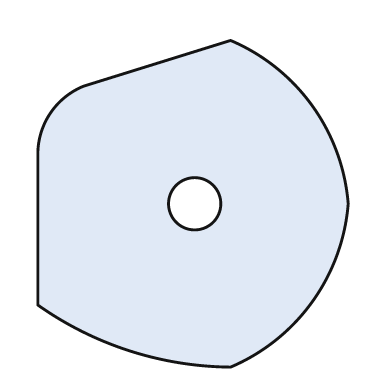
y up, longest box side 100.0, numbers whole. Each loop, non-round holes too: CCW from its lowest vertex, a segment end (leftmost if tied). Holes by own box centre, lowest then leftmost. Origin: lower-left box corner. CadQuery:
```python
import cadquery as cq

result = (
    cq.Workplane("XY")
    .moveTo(59.0, 0.0)
    .threePointArc((84.0, 20.0), (95.0, 50.0))
    .threePointArc((84.0, 80.0), (59.0, 100.0))
    .lineTo(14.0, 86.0)
    .threePointArc((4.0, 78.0), (0.0, 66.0))
    .lineTo(0.0, 19.0)
    .threePointArc((28.0, 5.0), (59.0, 0.0))
    .close()
    .moveTo(48.0, 50.0)
    .circle(8.0)
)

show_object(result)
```